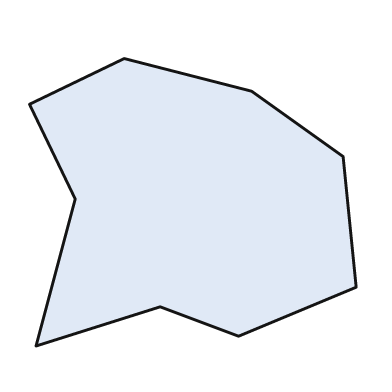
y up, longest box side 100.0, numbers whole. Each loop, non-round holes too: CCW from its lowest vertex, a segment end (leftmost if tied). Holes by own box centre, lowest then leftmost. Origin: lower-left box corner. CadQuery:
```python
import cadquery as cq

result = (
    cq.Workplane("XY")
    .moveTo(2.0, 0.0)
    .lineTo(40.0, 12.0)
    .lineTo(64.0, 3.0)
    .lineTo(100.0, 18.0)
    .lineTo(96.0, 58.0)
    .lineTo(68.0, 78.0)
    .lineTo(29.0, 88.0)
    .lineTo(0.0, 74.0)
    .lineTo(14.0, 45.0)
    .close()
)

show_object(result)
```